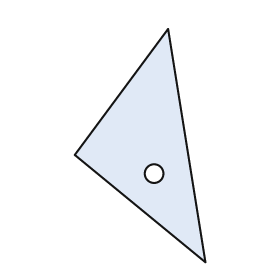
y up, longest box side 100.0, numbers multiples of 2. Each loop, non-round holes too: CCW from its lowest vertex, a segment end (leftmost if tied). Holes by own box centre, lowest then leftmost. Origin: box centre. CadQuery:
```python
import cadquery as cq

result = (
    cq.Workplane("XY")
    .moveTo(28.0, -50.0)
    .lineTo(12.0, 50.0)
    .lineTo(-28.0, -4.0)
    .close()
    .moveTo(6.0, -12.0)
    .circle(4.0)
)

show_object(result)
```